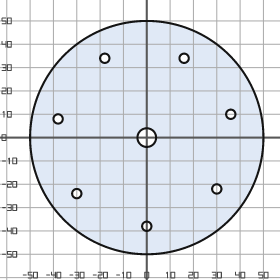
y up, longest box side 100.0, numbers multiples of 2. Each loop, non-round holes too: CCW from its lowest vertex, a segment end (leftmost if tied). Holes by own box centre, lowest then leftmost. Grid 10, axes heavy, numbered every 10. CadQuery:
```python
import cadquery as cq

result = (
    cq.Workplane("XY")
    .moveTo(0.0, 0.0)
    .circle(50.0)
    .moveTo(0.0, -38.0)
    .circle(2.0)
    .moveTo(-30.0, -24.0)
    .circle(2.0)
    .moveTo(30.0, -22.0)
    .circle(2.0)
    .moveTo(0.0, 0.0)
    .circle(4.0)
    .moveTo(-38.0, 8.0)
    .circle(2.0)
    .moveTo(36.0, 10.0)
    .circle(2.0)
    .moveTo(-18.0, 34.0)
    .circle(2.0)
    .moveTo(16.0, 34.0)
    .circle(2.0)
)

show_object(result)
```